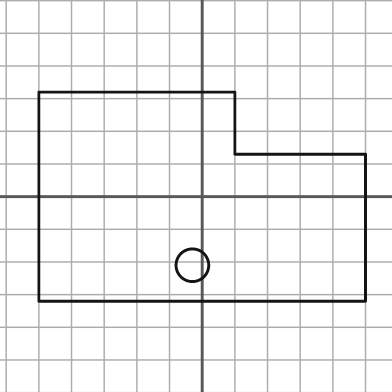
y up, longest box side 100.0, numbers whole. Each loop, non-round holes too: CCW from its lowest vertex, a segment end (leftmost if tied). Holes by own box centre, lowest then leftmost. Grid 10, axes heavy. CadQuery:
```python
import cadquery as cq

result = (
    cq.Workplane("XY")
    .moveTo(-50.0, -32.0)
    .lineTo(50.0, -32.0)
    .lineTo(50.0, 13.0)
    .lineTo(10.0, 13.0)
    .lineTo(10.0, 32.0)
    .lineTo(-50.0, 32.0)
    .close()
    .moveTo(-3.0, -21.0)
    .circle(5.0)
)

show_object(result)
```